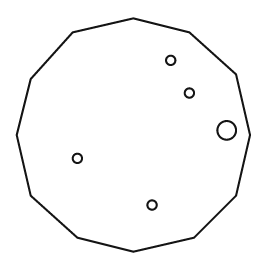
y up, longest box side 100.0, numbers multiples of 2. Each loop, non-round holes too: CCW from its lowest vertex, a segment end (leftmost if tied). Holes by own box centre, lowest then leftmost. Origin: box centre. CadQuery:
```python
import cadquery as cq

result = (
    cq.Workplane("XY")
    .moveTo(0.0, -50.0)
    .lineTo(26.0, -44.0)
    .lineTo(44.0, -26.0)
    .lineTo(50.0, 0.0)
    .lineTo(44.0, 26.0)
    .lineTo(24.0, 44.0)
    .lineTo(0.0, 50.0)
    .lineTo(-26.0, 44.0)
    .lineTo(-44.0, 24.0)
    .lineTo(-50.0, 0.0)
    .lineTo(-44.0, -26.0)
    .lineTo(-24.0, -44.0)
    .close()
    .moveTo(8.0, -30.0)
    .circle(2.0)
    .moveTo(-24.0, -10.0)
    .circle(2.0)
    .moveTo(40.0, 2.0)
    .circle(4.0)
    .moveTo(24.0, 18.0)
    .circle(2.0)
    .moveTo(16.0, 32.0)
    .circle(2.0)
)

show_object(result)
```